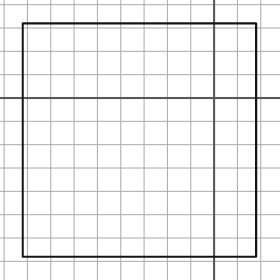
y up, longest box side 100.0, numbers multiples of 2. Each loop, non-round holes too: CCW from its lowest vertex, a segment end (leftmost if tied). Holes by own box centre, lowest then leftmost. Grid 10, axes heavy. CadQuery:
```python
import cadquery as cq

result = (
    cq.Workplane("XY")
    .moveTo(-82.0, -68.0)
    .lineTo(18.0, -68.0)
    .lineTo(18.0, 32.0)
    .lineTo(-82.0, 32.0)
    .close()
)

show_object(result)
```